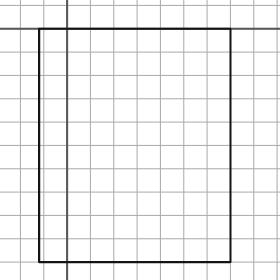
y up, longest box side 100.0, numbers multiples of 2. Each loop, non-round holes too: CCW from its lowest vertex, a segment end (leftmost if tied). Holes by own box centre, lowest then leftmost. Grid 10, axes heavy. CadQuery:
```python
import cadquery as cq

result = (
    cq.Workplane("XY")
    .moveTo(-12.0, -100.0)
    .lineTo(70.0, -100.0)
    .lineTo(70.0, 0.0)
    .lineTo(-12.0, 0.0)
    .close()
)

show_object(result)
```